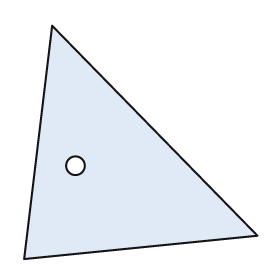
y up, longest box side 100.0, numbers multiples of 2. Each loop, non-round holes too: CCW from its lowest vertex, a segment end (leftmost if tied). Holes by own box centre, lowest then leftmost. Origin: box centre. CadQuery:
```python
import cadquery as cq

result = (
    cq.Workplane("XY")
    .moveTo(-50.0, -50.0)
    .lineTo(50.0, -40.0)
    .lineTo(-38.0, 50.0)
    .close()
    .moveTo(-28.0, -10.0)
    .circle(4.0)
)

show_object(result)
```